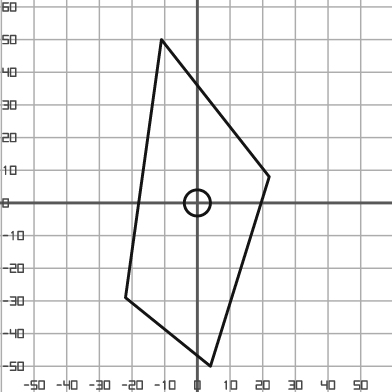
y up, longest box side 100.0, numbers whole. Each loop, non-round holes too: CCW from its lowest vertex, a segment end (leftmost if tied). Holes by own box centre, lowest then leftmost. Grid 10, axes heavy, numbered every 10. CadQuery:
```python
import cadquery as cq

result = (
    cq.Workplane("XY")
    .moveTo(4.0, -50.0)
    .lineTo(22.0, 8.0)
    .lineTo(-11.0, 50.0)
    .lineTo(-22.0, -29.0)
    .close()
    .moveTo(0.0, 0.0)
    .circle(4.0)
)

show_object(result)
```